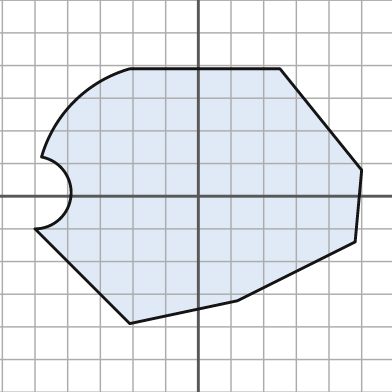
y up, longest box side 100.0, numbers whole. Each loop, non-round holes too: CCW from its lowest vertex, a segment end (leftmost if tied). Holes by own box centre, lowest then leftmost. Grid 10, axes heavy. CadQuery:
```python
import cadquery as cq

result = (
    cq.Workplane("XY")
    .moveTo(-21.0, -39.0)
    .lineTo(12.0, -32.0)
    .lineTo(48.0, -14.0)
    .lineTo(50.0, 8.0)
    .lineTo(25.0, 39.0)
    .lineTo(-21.0, 39.0)
    .threePointArc((-38.0, 29.0), (-48.0, 12.0))
    .threePointArc((-39.0, 0.0), (-50.0, -10.0))
    .close()
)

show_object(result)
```